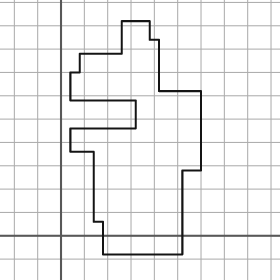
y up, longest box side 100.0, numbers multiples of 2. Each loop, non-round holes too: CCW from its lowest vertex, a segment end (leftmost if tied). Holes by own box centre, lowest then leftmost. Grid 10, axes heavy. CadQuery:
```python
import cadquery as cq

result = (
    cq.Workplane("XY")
    .moveTo(18.0, -8.0)
    .lineTo(52.0, -8.0)
    .lineTo(52.0, 28.0)
    .lineTo(60.0, 28.0)
    .lineTo(60.0, 62.0)
    .lineTo(42.0, 62.0)
    .lineTo(42.0, 84.0)
    .lineTo(38.0, 84.0)
    .lineTo(38.0, 92.0)
    .lineTo(26.0, 92.0)
    .lineTo(26.0, 78.0)
    .lineTo(8.0, 78.0)
    .lineTo(8.0, 70.0)
    .lineTo(4.0, 70.0)
    .lineTo(4.0, 58.0)
    .lineTo(32.0, 58.0)
    .lineTo(32.0, 46.0)
    .lineTo(4.0, 46.0)
    .lineTo(4.0, 36.0)
    .lineTo(14.0, 36.0)
    .lineTo(14.0, 6.0)
    .lineTo(18.0, 6.0)
    .close()
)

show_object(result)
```